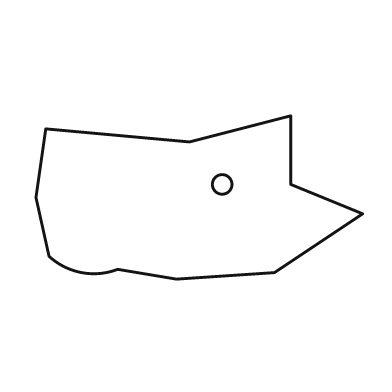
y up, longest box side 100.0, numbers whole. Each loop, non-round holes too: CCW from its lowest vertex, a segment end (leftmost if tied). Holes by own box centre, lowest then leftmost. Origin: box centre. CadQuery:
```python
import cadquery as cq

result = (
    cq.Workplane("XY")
    .moveTo(-7.0, -25.0)
    .lineTo(23.0, -23.0)
    .lineTo(50.0, -5.0)
    .lineTo(28.0, 4.0)
    .lineTo(28.0, 25.0)
    .lineTo(-3.0, 17.0)
    .lineTo(-47.0, 21.0)
    .lineTo(-50.0, 0.0)
    .lineTo(-46.0, -18.0)
    .threePointArc((-36.0, -23.0), (-25.0, -22.0))
    .close()
    .moveTo(7.0, 4.0)
    .circle(3.0)
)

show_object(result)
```